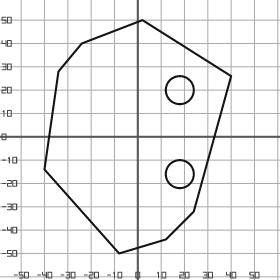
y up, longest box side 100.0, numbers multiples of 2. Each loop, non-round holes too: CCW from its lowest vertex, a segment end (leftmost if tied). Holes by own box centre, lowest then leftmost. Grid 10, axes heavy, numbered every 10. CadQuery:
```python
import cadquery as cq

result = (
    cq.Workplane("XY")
    .moveTo(-8.0, -50.0)
    .lineTo(12.0, -44.0)
    .lineTo(24.0, -32.0)
    .lineTo(40.0, 26.0)
    .lineTo(2.0, 50.0)
    .lineTo(-24.0, 40.0)
    .lineTo(-34.0, 28.0)
    .lineTo(-40.0, -14.0)
    .close()
    .moveTo(18.0, -16.0)
    .circle(6.0)
    .moveTo(18.0, 20.0)
    .circle(6.0)
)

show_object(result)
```